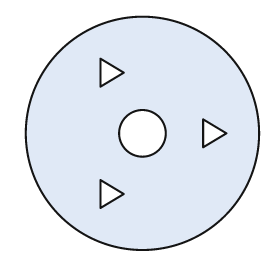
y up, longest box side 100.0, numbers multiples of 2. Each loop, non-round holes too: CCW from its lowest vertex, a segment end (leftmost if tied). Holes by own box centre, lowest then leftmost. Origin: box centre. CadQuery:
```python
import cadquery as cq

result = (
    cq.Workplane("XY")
    .moveTo(0.0, 0.0)
    .circle(50.0)
    .moveTo(-18.0, -32.0)
    .lineTo(-8.0, -26.0)
    .lineTo(-18.0, -20.0)
    .close()
    .moveTo(0.0, 0.0)
    .circle(10.0)
    .moveTo(26.0, -6.0)
    .lineTo(36.0, 0.0)
    .lineTo(26.0, 6.0)
    .close()
    .moveTo(-18.0, 20.0)
    .lineTo(-8.0, 26.0)
    .lineTo(-18.0, 32.0)
    .close()
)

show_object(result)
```